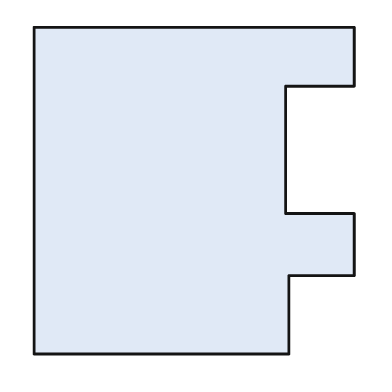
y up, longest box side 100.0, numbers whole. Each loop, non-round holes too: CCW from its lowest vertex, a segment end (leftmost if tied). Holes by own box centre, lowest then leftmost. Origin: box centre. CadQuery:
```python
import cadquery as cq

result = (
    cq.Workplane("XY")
    .moveTo(-49.0, -50.0)
    .lineTo(29.0, -50.0)
    .lineTo(29.0, -26.0)
    .lineTo(49.0, -26.0)
    .lineTo(49.0, -7.0)
    .lineTo(28.0, -7.0)
    .lineTo(28.0, 32.0)
    .lineTo(49.0, 32.0)
    .lineTo(49.0, 50.0)
    .lineTo(-49.0, 50.0)
    .close()
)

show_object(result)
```